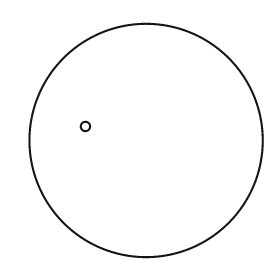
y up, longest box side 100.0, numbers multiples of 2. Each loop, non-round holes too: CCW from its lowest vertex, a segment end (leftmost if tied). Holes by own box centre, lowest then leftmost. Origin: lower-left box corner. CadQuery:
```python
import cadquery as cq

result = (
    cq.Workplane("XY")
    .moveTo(50.0, 50.0)
    .circle(50.0)
    .moveTo(24.0, 56.0)
    .circle(2.0)
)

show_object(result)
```